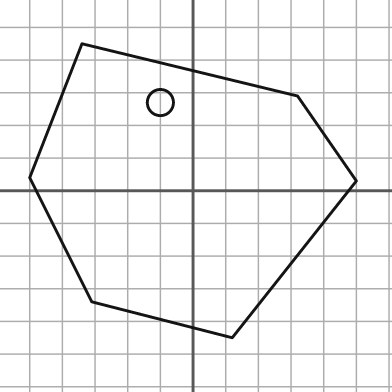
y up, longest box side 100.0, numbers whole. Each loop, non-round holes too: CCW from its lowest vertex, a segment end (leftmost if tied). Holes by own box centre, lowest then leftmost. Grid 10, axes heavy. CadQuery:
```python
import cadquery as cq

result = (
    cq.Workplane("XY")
    .moveTo(12.0, -45.0)
    .lineTo(50.0, 3.0)
    .lineTo(32.0, 29.0)
    .lineTo(-34.0, 45.0)
    .lineTo(-50.0, 4.0)
    .lineTo(-31.0, -34.0)
    .close()
    .moveTo(-10.0, 27.0)
    .circle(4.0)
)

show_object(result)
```